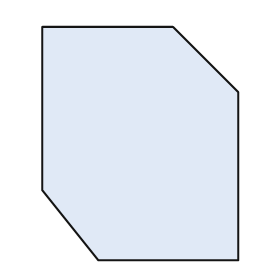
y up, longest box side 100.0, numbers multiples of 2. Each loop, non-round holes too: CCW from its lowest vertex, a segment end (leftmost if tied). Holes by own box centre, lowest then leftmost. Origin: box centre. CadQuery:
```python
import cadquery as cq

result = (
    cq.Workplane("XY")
    .moveTo(-18.0, -50.0)
    .lineTo(42.0, -50.0)
    .lineTo(42.0, 22.0)
    .lineTo(14.0, 50.0)
    .lineTo(-42.0, 50.0)
    .lineTo(-42.0, -20.0)
    .close()
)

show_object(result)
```